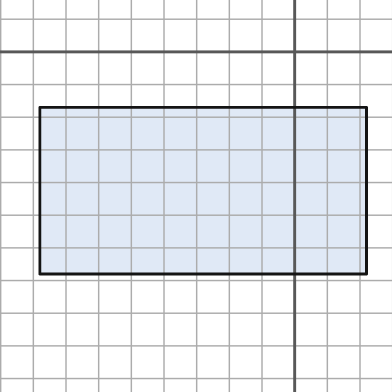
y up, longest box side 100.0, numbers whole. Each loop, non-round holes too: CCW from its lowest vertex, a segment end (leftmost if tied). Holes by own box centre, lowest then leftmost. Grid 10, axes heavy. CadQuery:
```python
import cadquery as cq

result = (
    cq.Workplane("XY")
    .moveTo(-78.0, -68.0)
    .lineTo(22.0, -68.0)
    .lineTo(22.0, -17.0)
    .lineTo(-78.0, -17.0)
    .close()
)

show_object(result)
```